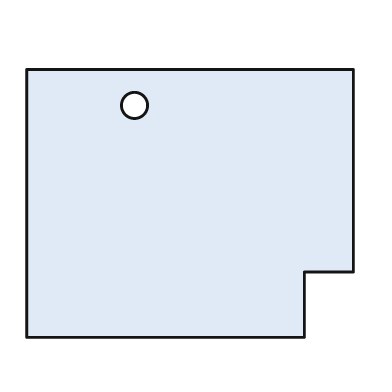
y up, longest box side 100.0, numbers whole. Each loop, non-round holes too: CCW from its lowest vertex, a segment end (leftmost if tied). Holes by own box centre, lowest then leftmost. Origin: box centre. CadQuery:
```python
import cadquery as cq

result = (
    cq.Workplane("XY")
    .moveTo(-50.0, -41.0)
    .lineTo(35.0, -41.0)
    .lineTo(35.0, -21.0)
    .lineTo(50.0, -21.0)
    .lineTo(50.0, 41.0)
    .lineTo(-50.0, 41.0)
    .close()
    .moveTo(-17.0, 30.0)
    .circle(4.0)
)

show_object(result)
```